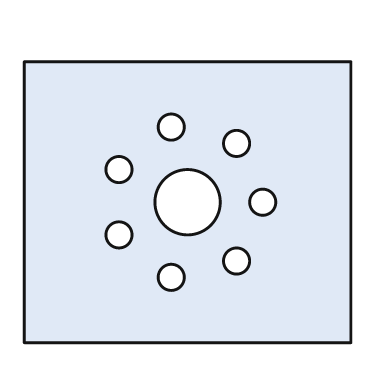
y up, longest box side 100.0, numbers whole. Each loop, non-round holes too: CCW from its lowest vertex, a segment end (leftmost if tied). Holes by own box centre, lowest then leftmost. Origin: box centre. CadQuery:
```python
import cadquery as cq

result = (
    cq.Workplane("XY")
    .moveTo(-50.0, -43.0)
    .lineTo(50.0, -43.0)
    .lineTo(50.0, 43.0)
    .lineTo(-50.0, 43.0)
    .close()
    .moveTo(-5.0, -23.0)
    .circle(4.0)
    .moveTo(15.0, -18.0)
    .circle(4.0)
    .moveTo(-21.0, -10.0)
    .circle(4.0)
    .moveTo(0.0, 0.0)
    .circle(10.0)
    .moveTo(23.0, 0.0)
    .circle(4.0)
    .moveTo(-21.0, 10.0)
    .circle(4.0)
    .moveTo(15.0, 18.0)
    .circle(4.0)
    .moveTo(-5.0, 23.0)
    .circle(4.0)
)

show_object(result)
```